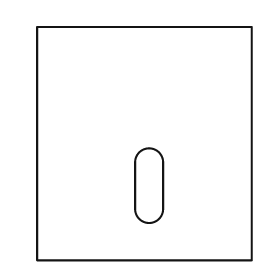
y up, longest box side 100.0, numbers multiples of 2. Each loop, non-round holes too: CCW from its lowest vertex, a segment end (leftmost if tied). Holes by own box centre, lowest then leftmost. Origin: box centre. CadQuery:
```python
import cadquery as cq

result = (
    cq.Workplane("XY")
    .moveTo(-46.0, -50.0)
    .lineTo(46.0, -50.0)
    .lineTo(46.0, 50.0)
    .lineTo(-46.0, 50.0)
    .close()
    .moveTo(-4.0, -28.0)
    .threePointArc((2.0, -34.0), (8.0, -28.0))
    .lineTo(8.0, -8.0)
    .threePointArc((2.0, -2.0), (-4.0, -8.0))
    .close()
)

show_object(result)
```